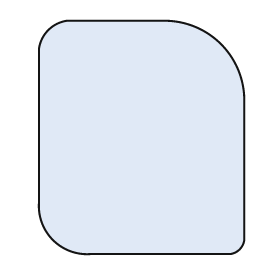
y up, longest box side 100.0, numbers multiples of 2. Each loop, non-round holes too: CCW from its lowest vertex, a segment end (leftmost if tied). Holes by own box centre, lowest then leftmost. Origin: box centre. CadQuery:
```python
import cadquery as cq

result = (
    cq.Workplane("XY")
    .moveTo(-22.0, -50.0)
    .lineTo(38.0, -50.0)
    .threePointArc((42.0, -48.0), (44.0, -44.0))
    .lineTo(44.0, 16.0)
    .threePointArc((34.0, 40.0), (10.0, 50.0))
    .lineTo(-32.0, 50.0)
    .threePointArc((-40.0, 46.0), (-44.0, 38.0))
    .lineTo(-44.0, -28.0)
    .threePointArc((-38.0, -44.0), (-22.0, -50.0))
    .close()
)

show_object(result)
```